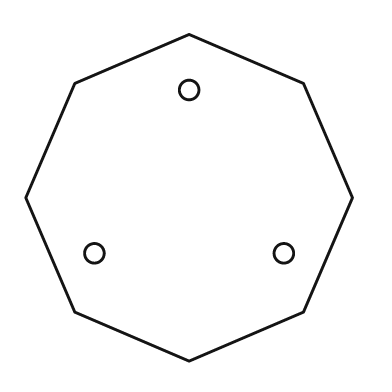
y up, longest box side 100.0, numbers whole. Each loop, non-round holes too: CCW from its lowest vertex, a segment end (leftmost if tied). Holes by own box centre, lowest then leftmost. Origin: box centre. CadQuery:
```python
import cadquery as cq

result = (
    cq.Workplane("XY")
    .moveTo(0.0, -50.0)
    .lineTo(35.0, -35.0)
    .lineTo(50.0, 0.0)
    .lineTo(35.0, 35.0)
    .lineTo(0.0, 50.0)
    .lineTo(-35.0, 35.0)
    .lineTo(-50.0, 0.0)
    .lineTo(-35.0, -35.0)
    .close()
    .moveTo(-29.0, -17.0)
    .circle(3.0)
    .moveTo(29.0, -17.0)
    .circle(3.0)
    .moveTo(0.0, 33.0)
    .circle(3.0)
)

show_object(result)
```